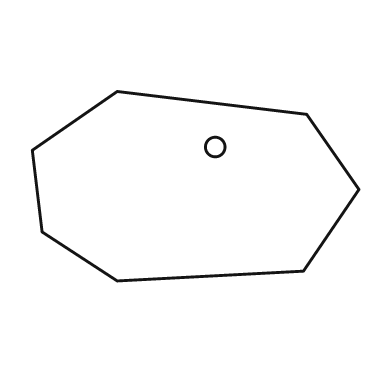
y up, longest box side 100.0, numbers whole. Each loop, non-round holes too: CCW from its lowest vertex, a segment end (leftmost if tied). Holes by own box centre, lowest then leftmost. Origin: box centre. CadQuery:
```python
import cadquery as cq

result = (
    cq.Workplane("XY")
    .moveTo(-24.0, -29.0)
    .lineTo(33.0, -26.0)
    .lineTo(50.0, -1.0)
    .lineTo(34.0, 22.0)
    .lineTo(-24.0, 29.0)
    .lineTo(-50.0, 11.0)
    .lineTo(-47.0, -14.0)
    .close()
    .moveTo(6.0, 12.0)
    .circle(3.0)
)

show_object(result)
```